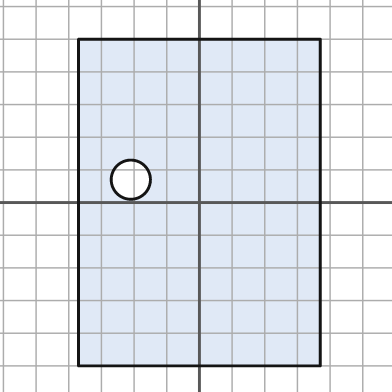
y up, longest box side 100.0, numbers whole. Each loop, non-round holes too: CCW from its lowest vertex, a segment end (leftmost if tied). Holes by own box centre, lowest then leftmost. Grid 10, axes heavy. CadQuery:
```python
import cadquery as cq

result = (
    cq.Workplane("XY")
    .moveTo(-37.0, -50.0)
    .lineTo(37.0, -50.0)
    .lineTo(37.0, 50.0)
    .lineTo(-37.0, 50.0)
    .close()
    .moveTo(-21.0, 7.0)
    .circle(6.0)
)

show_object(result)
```